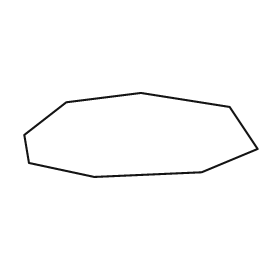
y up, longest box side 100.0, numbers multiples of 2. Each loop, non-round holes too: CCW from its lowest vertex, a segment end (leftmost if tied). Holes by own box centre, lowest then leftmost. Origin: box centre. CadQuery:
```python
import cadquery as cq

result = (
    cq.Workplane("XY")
    .moveTo(-20.0, -18.0)
    .lineTo(26.0, -16.0)
    .lineTo(50.0, -6.0)
    .lineTo(38.0, 12.0)
    .lineTo(0.0, 18.0)
    .lineTo(-32.0, 14.0)
    .lineTo(-50.0, 0.0)
    .lineTo(-48.0, -12.0)
    .close()
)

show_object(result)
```